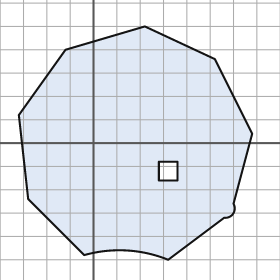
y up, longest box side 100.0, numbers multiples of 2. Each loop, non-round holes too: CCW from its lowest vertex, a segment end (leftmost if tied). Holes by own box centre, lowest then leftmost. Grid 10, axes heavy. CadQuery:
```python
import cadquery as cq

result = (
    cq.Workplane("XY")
    .moveTo(32.0, -50.0)
    .lineTo(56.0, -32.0)
    .threePointArc((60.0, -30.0), (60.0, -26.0))
    .lineTo(68.0, 4.0)
    .lineTo(52.0, 36.0)
    .lineTo(22.0, 50.0)
    .lineTo(-12.0, 40.0)
    .lineTo(-32.0, 12.0)
    .lineTo(-28.0, -24.0)
    .lineTo(-4.0, -48.0)
    .threePointArc((14.0, -46.0), (32.0, -50.0))
    .close()
    .moveTo(28.0, -16.0)
    .lineTo(36.0, -16.0)
    .lineTo(36.0, -8.0)
    .lineTo(28.0, -8.0)
    .close()
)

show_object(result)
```